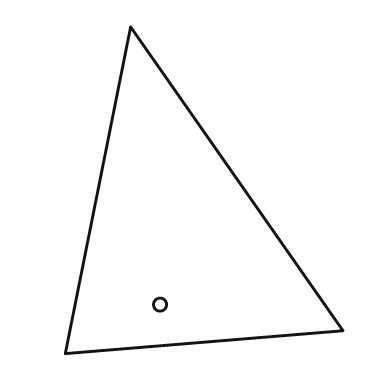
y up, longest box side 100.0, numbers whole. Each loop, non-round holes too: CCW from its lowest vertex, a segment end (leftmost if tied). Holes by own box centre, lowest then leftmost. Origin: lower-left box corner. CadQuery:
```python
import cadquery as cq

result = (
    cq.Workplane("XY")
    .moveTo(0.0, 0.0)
    .lineTo(85.0, 7.0)
    .lineTo(20.0, 100.0)
    .close()
    .moveTo(29.0, 15.0)
    .circle(2.0)
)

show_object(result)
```